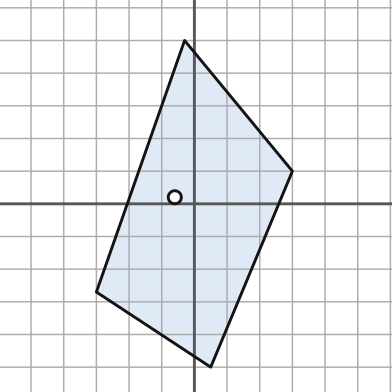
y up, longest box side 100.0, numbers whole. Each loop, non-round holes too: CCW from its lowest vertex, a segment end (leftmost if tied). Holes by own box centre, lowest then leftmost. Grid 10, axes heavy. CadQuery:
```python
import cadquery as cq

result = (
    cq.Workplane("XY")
    .moveTo(5.0, -50.0)
    .lineTo(30.0, 10.0)
    .lineTo(-3.0, 50.0)
    .lineTo(-30.0, -27.0)
    .close()
    .moveTo(-6.0, 2.0)
    .circle(2.0)
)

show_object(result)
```